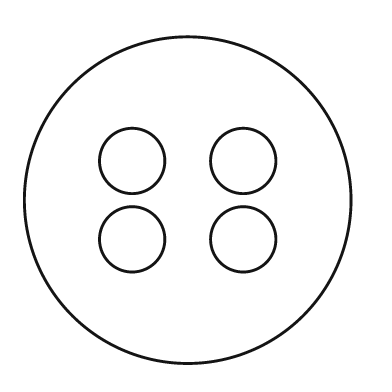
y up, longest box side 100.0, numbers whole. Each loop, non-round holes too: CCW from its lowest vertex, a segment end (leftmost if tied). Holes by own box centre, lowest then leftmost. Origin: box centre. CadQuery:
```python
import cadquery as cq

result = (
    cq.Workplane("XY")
    .moveTo(0.0, 0.0)
    .circle(50.0)
    .moveTo(-17.0, -12.0)
    .circle(10.0)
    .moveTo(17.0, -12.0)
    .circle(10.0)
    .moveTo(-17.0, 12.0)
    .circle(10.0)
    .moveTo(17.0, 12.0)
    .circle(10.0)
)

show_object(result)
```